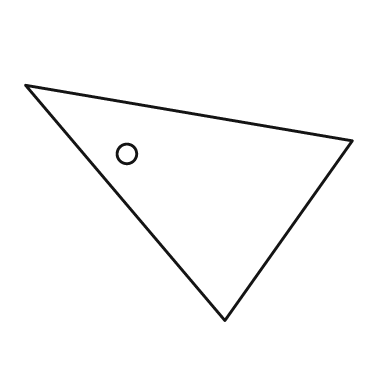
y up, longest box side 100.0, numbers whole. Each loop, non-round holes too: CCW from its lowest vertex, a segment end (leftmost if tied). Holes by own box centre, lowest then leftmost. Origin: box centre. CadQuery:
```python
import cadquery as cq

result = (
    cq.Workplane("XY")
    .moveTo(11.0, -36.0)
    .lineTo(50.0, 19.0)
    .lineTo(-50.0, 36.0)
    .close()
    .moveTo(-19.0, 15.0)
    .circle(3.0)
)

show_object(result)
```